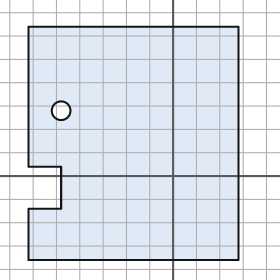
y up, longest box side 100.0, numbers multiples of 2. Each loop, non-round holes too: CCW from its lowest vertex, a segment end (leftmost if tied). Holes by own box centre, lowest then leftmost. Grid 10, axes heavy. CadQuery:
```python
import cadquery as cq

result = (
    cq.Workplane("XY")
    .moveTo(-62.0, -36.0)
    .lineTo(28.0, -36.0)
    .lineTo(28.0, 64.0)
    .lineTo(-62.0, 64.0)
    .lineTo(-62.0, 4.0)
    .lineTo(-48.0, 4.0)
    .lineTo(-48.0, -14.0)
    .lineTo(-62.0, -14.0)
    .close()
    .moveTo(-48.0, 28.0)
    .circle(4.0)
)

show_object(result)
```